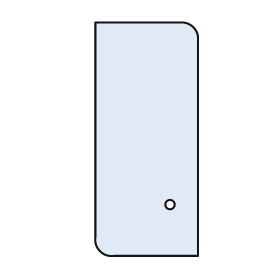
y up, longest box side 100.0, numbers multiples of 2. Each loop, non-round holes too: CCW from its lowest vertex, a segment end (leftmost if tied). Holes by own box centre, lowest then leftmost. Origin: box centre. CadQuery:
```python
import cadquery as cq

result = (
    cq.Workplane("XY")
    .moveTo(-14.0, -50.0)
    .lineTo(22.0, -50.0)
    .lineTo(22.0, 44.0)
    .threePointArc((20.0, 48.0), (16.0, 50.0))
    .lineTo(-22.0, 50.0)
    .lineTo(-22.0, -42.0)
    .threePointArc((-20.0, -48.0), (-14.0, -50.0))
    .close()
    .moveTo(10.0, -28.0)
    .circle(2.0)
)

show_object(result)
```